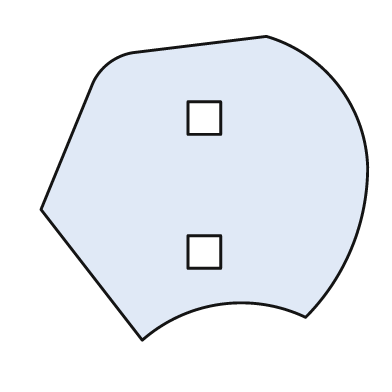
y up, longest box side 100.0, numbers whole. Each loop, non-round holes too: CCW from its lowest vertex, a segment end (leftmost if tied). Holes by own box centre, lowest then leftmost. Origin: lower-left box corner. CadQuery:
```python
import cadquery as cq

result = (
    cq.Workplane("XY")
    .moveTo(31.0, 0.0)
    .threePointArc((55.0, 11.0), (81.0, 7.0))
    .threePointArc((95.0, 28.0), (100.0, 53.0))
    .threePointArc((91.0, 78.0), (69.0, 93.0))
    .lineTo(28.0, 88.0)
    .threePointArc((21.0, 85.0), (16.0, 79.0))
    .lineTo(0.0, 40.0)
    .close()
    .moveTo(45.0, 22.0)
    .lineTo(55.0, 22.0)
    .lineTo(55.0, 32.0)
    .lineTo(45.0, 32.0)
    .close()
    .moveTo(45.0, 63.0)
    .lineTo(55.0, 63.0)
    .lineTo(55.0, 73.0)
    .lineTo(45.0, 73.0)
    .close()
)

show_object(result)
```